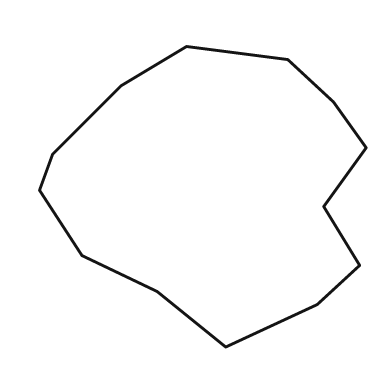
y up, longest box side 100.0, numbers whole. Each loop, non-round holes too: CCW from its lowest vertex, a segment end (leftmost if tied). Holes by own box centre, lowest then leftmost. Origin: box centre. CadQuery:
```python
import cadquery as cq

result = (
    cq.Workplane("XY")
    .moveTo(7.0, -46.0)
    .lineTo(35.0, -33.0)
    .lineTo(48.0, -21.0)
    .lineTo(37.0, -3.0)
    .lineTo(50.0, 15.0)
    .lineTo(40.0, 29.0)
    .lineTo(26.0, 42.0)
    .lineTo(-5.0, 46.0)
    .lineTo(-25.0, 34.0)
    .lineTo(-46.0, 13.0)
    .lineTo(-50.0, 2.0)
    .lineTo(-37.0, -18.0)
    .lineTo(-14.0, -29.0)
    .close()
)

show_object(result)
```